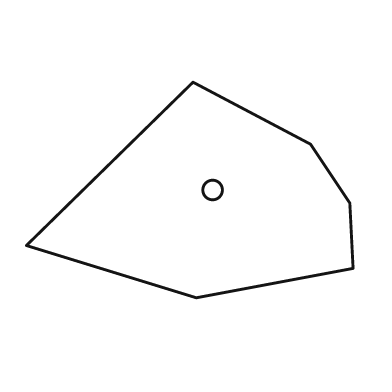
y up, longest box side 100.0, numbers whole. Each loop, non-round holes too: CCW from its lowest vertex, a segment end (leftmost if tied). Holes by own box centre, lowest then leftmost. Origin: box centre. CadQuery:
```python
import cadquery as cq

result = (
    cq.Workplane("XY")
    .moveTo(2.0, -33.0)
    .lineTo(50.0, -24.0)
    .lineTo(49.0, -4.0)
    .lineTo(37.0, 14.0)
    .lineTo(1.0, 33.0)
    .lineTo(-50.0, -17.0)
    .close()
    .moveTo(7.0, 0.0)
    .circle(3.0)
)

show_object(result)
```